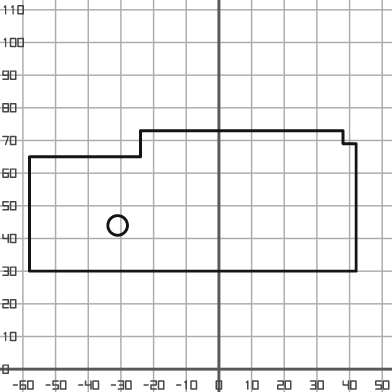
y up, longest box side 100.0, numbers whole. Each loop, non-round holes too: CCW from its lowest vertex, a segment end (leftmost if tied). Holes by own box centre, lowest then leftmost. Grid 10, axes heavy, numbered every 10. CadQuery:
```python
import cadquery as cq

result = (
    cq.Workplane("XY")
    .moveTo(-58.0, 30.0)
    .lineTo(42.0, 30.0)
    .lineTo(42.0, 69.0)
    .lineTo(38.0, 69.0)
    .lineTo(38.0, 73.0)
    .lineTo(-24.0, 73.0)
    .lineTo(-24.0, 65.0)
    .lineTo(-58.0, 65.0)
    .close()
    .moveTo(-31.0, 44.0)
    .circle(3.0)
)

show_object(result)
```